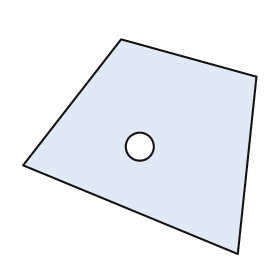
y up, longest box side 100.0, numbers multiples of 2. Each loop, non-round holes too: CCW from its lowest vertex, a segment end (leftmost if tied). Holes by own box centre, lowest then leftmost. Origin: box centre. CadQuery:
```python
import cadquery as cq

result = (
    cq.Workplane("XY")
    .moveTo(42.0, -46.0)
    .lineTo(50.0, 30.0)
    .lineTo(-8.0, 46.0)
    .lineTo(-50.0, -8.0)
    .close()
    .moveTo(0.0, 0.0)
    .circle(6.0)
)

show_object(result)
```